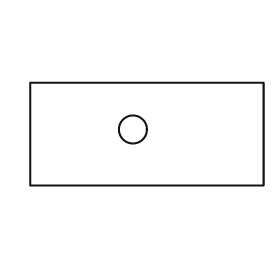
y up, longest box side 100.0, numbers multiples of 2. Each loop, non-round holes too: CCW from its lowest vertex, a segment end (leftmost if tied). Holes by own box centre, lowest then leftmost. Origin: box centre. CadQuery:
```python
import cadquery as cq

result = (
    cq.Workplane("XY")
    .moveTo(-50.0, -22.0)
    .lineTo(50.0, -22.0)
    .lineTo(50.0, 22.0)
    .lineTo(-50.0, 22.0)
    .close()
    .moveTo(-6.0, 2.0)
    .circle(6.0)
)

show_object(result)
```